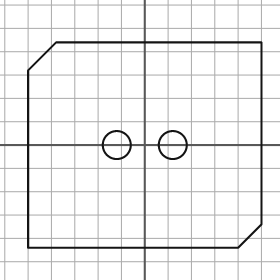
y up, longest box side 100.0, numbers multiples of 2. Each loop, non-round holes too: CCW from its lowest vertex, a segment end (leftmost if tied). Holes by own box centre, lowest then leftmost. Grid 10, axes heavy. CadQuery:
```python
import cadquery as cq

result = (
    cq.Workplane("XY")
    .moveTo(-50.0, -44.0)
    .lineTo(40.0, -44.0)
    .lineTo(50.0, -34.0)
    .lineTo(50.0, 44.0)
    .lineTo(-38.0, 44.0)
    .lineTo(-50.0, 32.0)
    .close()
    .moveTo(-12.0, 0.0)
    .circle(6.0)
    .moveTo(12.0, 0.0)
    .circle(6.0)
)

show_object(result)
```